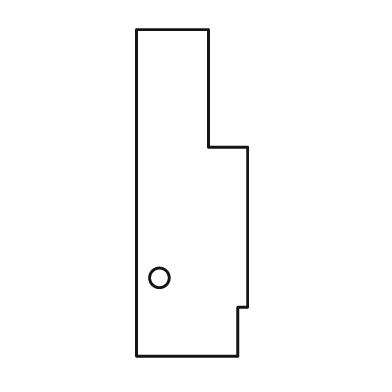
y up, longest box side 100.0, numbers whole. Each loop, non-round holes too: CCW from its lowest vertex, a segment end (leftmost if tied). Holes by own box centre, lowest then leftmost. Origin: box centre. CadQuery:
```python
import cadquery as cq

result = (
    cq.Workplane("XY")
    .moveTo(-17.0, -50.0)
    .lineTo(14.0, -50.0)
    .lineTo(14.0, -35.0)
    .lineTo(17.0, -35.0)
    .lineTo(17.0, 14.0)
    .lineTo(5.0, 14.0)
    .lineTo(5.0, 50.0)
    .lineTo(-17.0, 50.0)
    .close()
    .moveTo(-10.0, -26.0)
    .circle(3.0)
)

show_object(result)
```